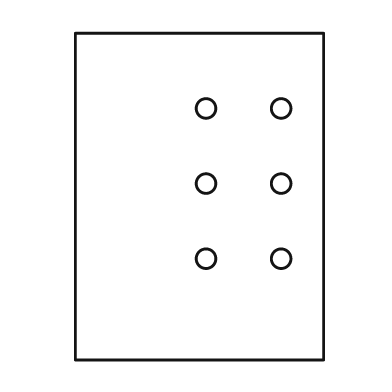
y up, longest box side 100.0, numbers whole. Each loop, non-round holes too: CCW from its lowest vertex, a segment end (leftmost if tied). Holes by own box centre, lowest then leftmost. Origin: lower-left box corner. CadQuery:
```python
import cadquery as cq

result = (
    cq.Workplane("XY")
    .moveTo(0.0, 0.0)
    .lineTo(76.0, 0.0)
    .lineTo(76.0, 100.0)
    .lineTo(0.0, 100.0)
    .close()
    .moveTo(40.0, 31.0)
    .circle(3.0)
    .moveTo(63.0, 31.0)
    .circle(3.0)
    .moveTo(40.0, 54.0)
    .circle(3.0)
    .moveTo(63.0, 54.0)
    .circle(3.0)
    .moveTo(40.0, 77.0)
    .circle(3.0)
    .moveTo(63.0, 77.0)
    .circle(3.0)
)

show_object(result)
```